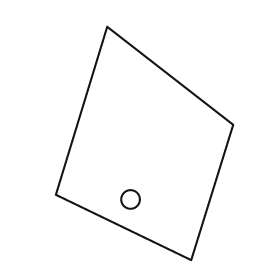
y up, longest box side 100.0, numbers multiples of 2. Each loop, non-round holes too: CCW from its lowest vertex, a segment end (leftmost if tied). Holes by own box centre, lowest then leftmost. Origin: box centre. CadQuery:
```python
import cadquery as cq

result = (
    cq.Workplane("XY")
    .moveTo(20.0, -50.0)
    .lineTo(38.0, 8.0)
    .lineTo(-16.0, 50.0)
    .lineTo(-38.0, -22.0)
    .close()
    .moveTo(-6.0, -24.0)
    .circle(4.0)
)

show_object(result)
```